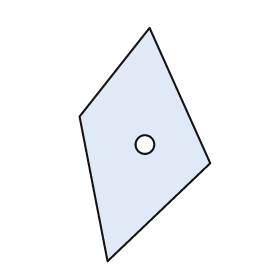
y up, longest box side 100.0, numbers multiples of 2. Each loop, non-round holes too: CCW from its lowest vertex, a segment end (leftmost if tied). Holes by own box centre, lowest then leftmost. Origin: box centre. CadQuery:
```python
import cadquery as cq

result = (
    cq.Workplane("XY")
    .moveTo(-16.0, -50.0)
    .lineTo(28.0, -8.0)
    .lineTo(2.0, 50.0)
    .lineTo(-28.0, 12.0)
    .close()
    .moveTo(0.0, 0.0)
    .circle(4.0)
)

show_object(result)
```